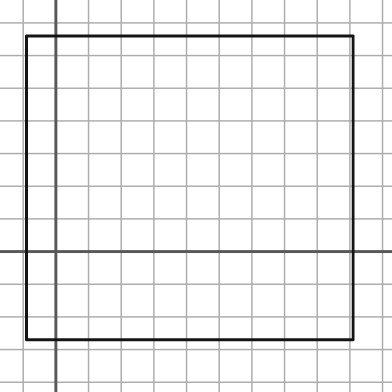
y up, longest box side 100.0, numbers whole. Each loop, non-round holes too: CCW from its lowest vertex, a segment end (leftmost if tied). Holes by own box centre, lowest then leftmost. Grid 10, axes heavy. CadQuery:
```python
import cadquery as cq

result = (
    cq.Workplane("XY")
    .moveTo(-9.0, -27.0)
    .lineTo(91.0, -27.0)
    .lineTo(91.0, 66.0)
    .lineTo(-9.0, 66.0)
    .close()
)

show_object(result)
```